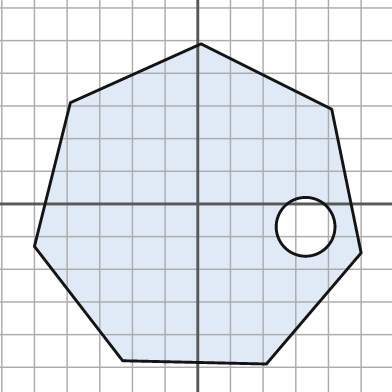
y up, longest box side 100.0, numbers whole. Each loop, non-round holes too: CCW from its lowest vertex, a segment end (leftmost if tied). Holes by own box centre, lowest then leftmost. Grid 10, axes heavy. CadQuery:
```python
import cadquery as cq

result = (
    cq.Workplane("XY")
    .moveTo(21.0, -49.0)
    .lineTo(50.0, -15.0)
    .lineTo(41.0, 29.0)
    .lineTo(1.0, 49.0)
    .lineTo(-39.0, 31.0)
    .lineTo(-50.0, -13.0)
    .lineTo(-23.0, -48.0)
    .close()
    .moveTo(33.0, -7.0)
    .circle(9.0)
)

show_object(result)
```